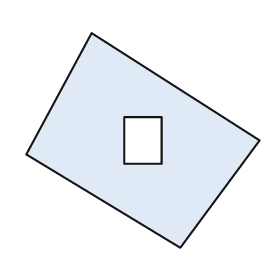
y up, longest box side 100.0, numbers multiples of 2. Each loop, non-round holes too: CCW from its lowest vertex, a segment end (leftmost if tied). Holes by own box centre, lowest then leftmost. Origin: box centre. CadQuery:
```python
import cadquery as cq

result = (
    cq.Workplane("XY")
    .moveTo(16.0, -46.0)
    .lineTo(50.0, 0.0)
    .lineTo(-22.0, 46.0)
    .lineTo(-50.0, -6.0)
    .close()
    .moveTo(-8.0, -10.0)
    .lineTo(8.0, -10.0)
    .lineTo(8.0, 10.0)
    .lineTo(-8.0, 10.0)
    .close()
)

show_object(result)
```